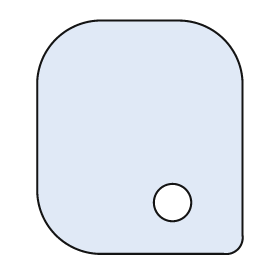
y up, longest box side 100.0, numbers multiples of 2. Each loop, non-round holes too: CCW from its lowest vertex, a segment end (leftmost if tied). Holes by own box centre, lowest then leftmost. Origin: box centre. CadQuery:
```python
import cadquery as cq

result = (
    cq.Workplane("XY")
    .moveTo(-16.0, -50.0)
    .lineTo(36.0, -50.0)
    .threePointArc((42.0, -48.0), (44.0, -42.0))
    .lineTo(44.0, 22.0)
    .threePointArc((36.0, 42.0), (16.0, 50.0))
    .lineTo(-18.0, 50.0)
    .threePointArc((-36.0, 42.0), (-44.0, 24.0))
    .lineTo(-44.0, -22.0)
    .threePointArc((-36.0, -42.0), (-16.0, -50.0))
    .close()
    .moveTo(14.0, -28.0)
    .circle(8.0)
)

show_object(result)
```